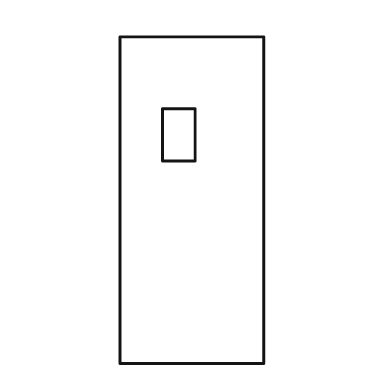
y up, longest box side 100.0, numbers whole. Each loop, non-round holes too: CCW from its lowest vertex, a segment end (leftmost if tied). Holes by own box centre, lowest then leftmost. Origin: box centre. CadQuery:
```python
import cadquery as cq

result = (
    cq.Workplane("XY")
    .moveTo(-22.0, -50.0)
    .lineTo(22.0, -50.0)
    .lineTo(22.0, 50.0)
    .lineTo(-22.0, 50.0)
    .close()
    .moveTo(-9.0, 12.0)
    .lineTo(1.0, 12.0)
    .lineTo(1.0, 28.0)
    .lineTo(-9.0, 28.0)
    .close()
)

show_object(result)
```